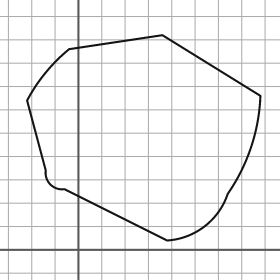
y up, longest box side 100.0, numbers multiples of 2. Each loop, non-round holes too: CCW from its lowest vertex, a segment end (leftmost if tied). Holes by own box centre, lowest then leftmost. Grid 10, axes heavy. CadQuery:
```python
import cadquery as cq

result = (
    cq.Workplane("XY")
    .moveTo(38.0, 4.0)
    .threePointArc((54.0, 10.0), (64.0, 24.0))
    .threePointArc((74.0, 44.0), (78.0, 66.0))
    .lineTo(36.0, 92.0)
    .lineTo(-4.0, 86.0)
    .threePointArc((-14.0, 76.0), (-22.0, 64.0))
    .lineTo(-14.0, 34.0)
    .threePointArc((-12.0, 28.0), (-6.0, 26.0))
    .close()
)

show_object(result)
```